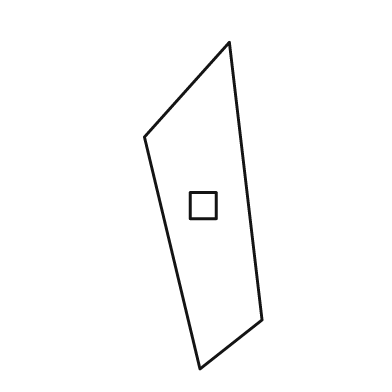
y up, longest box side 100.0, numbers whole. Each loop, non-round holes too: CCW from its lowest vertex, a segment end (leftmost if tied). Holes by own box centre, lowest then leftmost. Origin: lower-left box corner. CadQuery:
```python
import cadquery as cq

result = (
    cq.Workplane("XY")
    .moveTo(17.0, 0.0)
    .lineTo(36.0, 15.0)
    .lineTo(26.0, 100.0)
    .lineTo(0.0, 71.0)
    .close()
    .moveTo(14.0, 46.0)
    .lineTo(22.0, 46.0)
    .lineTo(22.0, 54.0)
    .lineTo(14.0, 54.0)
    .close()
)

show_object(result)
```